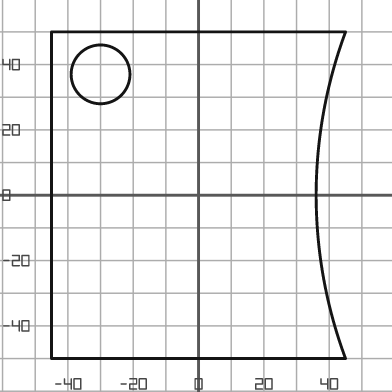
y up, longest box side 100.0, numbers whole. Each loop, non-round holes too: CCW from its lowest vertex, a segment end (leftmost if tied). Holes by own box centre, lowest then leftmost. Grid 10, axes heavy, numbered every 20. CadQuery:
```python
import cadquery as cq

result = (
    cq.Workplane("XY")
    .moveTo(-45.0, -50.0)
    .lineTo(45.0, -50.0)
    .threePointArc((36.0, 0.0), (45.0, 50.0))
    .lineTo(-45.0, 50.0)
    .close()
    .moveTo(-30.0, 37.0)
    .circle(9.0)
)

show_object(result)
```